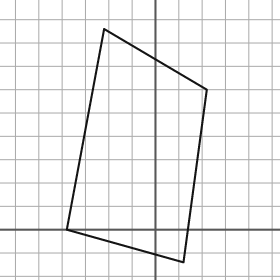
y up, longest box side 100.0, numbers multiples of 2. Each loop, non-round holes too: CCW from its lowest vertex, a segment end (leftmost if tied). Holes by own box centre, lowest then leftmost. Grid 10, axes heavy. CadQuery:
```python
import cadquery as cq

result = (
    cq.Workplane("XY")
    .moveTo(12.0, -14.0)
    .lineTo(22.0, 60.0)
    .lineTo(-22.0, 86.0)
    .lineTo(-38.0, 0.0)
    .close()
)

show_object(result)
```